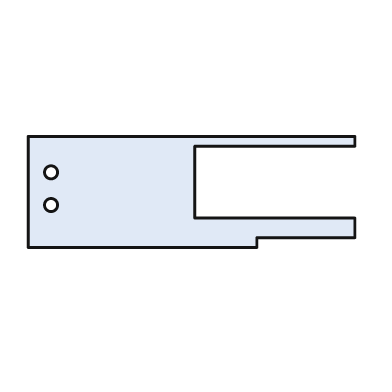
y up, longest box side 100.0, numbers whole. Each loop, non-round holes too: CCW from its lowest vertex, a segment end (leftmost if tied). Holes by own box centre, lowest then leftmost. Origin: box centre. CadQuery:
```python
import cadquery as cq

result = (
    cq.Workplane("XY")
    .moveTo(-50.0, -17.0)
    .lineTo(20.0, -17.0)
    .lineTo(20.0, -14.0)
    .lineTo(50.0, -14.0)
    .lineTo(50.0, -8.0)
    .lineTo(1.0, -8.0)
    .lineTo(1.0, 14.0)
    .lineTo(50.0, 14.0)
    .lineTo(50.0, 17.0)
    .lineTo(-50.0, 17.0)
    .close()
    .moveTo(-43.0, -4.0)
    .circle(2.0)
    .moveTo(-43.0, 6.0)
    .circle(2.0)
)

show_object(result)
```